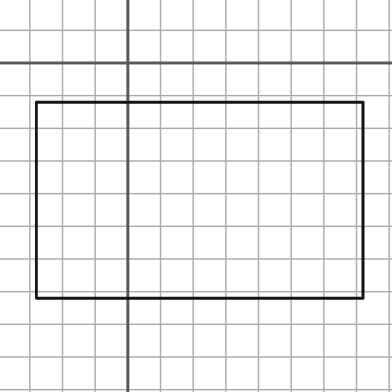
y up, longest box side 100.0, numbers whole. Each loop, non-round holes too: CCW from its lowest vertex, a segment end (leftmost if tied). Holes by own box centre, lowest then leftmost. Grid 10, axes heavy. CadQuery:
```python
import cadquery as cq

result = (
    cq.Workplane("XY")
    .moveTo(-28.0, -72.0)
    .lineTo(72.0, -72.0)
    .lineTo(72.0, -12.0)
    .lineTo(-28.0, -12.0)
    .close()
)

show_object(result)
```